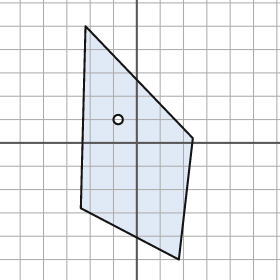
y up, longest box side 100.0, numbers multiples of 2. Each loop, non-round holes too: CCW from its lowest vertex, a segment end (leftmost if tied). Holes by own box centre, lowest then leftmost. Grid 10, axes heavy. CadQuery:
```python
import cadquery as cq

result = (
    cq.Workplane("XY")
    .moveTo(18.0, -50.0)
    .lineTo(24.0, 2.0)
    .lineTo(-22.0, 50.0)
    .lineTo(-24.0, -28.0)
    .close()
    .moveTo(-8.0, 10.0)
    .circle(2.0)
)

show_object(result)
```